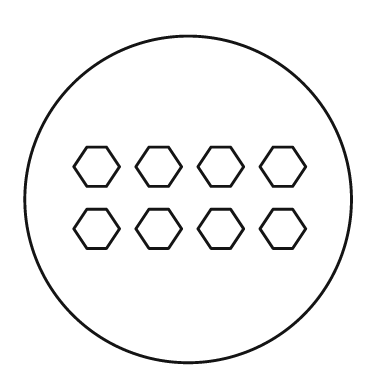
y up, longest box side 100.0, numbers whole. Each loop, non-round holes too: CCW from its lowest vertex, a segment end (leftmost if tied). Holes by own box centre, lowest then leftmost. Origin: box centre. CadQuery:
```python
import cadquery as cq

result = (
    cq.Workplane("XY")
    .moveTo(0.0, 0.0)
    .circle(50.0)
    .moveTo(-31.0, -15.0)
    .lineTo(-25.0, -15.0)
    .lineTo(-21.0, -9.0)
    .lineTo(-25.0, -3.0)
    .lineTo(-31.0, -3.0)
    .lineTo(-35.0, -9.0)
    .close()
    .moveTo(-12.0, -15.0)
    .lineTo(-6.0, -15.0)
    .lineTo(-2.0, -9.0)
    .lineTo(-6.0, -3.0)
    .lineTo(-12.0, -3.0)
    .lineTo(-16.0, -9.0)
    .close()
    .moveTo(7.0, -15.0)
    .lineTo(13.0, -15.0)
    .lineTo(17.0, -9.0)
    .lineTo(13.0, -3.0)
    .lineTo(7.0, -3.0)
    .lineTo(3.0, -9.0)
    .close()
    .moveTo(26.0, -15.0)
    .lineTo(32.0, -15.0)
    .lineTo(36.0, -9.0)
    .lineTo(32.0, -3.0)
    .lineTo(26.0, -3.0)
    .lineTo(22.0, -9.0)
    .close()
    .moveTo(-31.0, 4.0)
    .lineTo(-25.0, 4.0)
    .lineTo(-21.0, 10.0)
    .lineTo(-25.0, 16.0)
    .lineTo(-31.0, 16.0)
    .lineTo(-35.0, 10.0)
    .close()
    .moveTo(-12.0, 4.0)
    .lineTo(-6.0, 4.0)
    .lineTo(-2.0, 10.0)
    .lineTo(-6.0, 16.0)
    .lineTo(-12.0, 16.0)
    .lineTo(-16.0, 10.0)
    .close()
    .moveTo(7.0, 4.0)
    .lineTo(13.0, 4.0)
    .lineTo(17.0, 10.0)
    .lineTo(13.0, 16.0)
    .lineTo(7.0, 16.0)
    .lineTo(3.0, 10.0)
    .close()
    .moveTo(26.0, 4.0)
    .lineTo(32.0, 4.0)
    .lineTo(36.0, 10.0)
    .lineTo(32.0, 16.0)
    .lineTo(26.0, 16.0)
    .lineTo(22.0, 10.0)
    .close()
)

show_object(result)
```